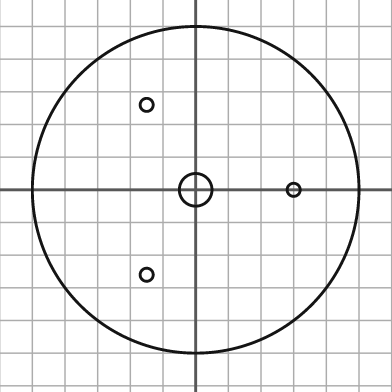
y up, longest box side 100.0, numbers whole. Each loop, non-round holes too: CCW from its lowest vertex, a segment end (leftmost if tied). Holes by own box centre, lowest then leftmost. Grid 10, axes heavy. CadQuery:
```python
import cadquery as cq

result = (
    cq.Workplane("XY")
    .moveTo(0.0, 0.0)
    .circle(50.0)
    .moveTo(-15.0, -26.0)
    .circle(2.0)
    .moveTo(0.0, 0.0)
    .circle(5.0)
    .moveTo(30.0, 0.0)
    .circle(2.0)
    .moveTo(-15.0, 26.0)
    .circle(2.0)
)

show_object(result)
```